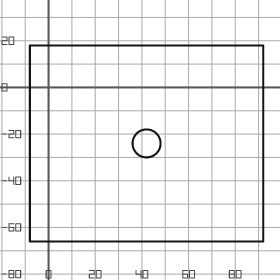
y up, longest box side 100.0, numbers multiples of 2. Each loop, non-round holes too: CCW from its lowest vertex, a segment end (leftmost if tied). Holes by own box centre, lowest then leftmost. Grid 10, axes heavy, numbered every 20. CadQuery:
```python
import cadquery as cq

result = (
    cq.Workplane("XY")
    .moveTo(-8.0, -66.0)
    .lineTo(92.0, -66.0)
    .lineTo(92.0, 18.0)
    .lineTo(-8.0, 18.0)
    .close()
    .moveTo(42.0, -24.0)
    .circle(6.0)
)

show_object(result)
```